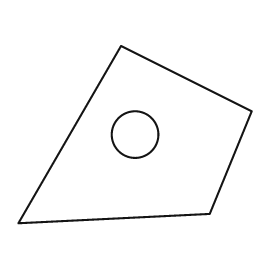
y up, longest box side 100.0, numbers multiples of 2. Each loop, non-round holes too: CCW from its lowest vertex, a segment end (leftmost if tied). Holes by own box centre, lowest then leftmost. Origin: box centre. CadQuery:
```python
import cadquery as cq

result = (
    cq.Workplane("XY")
    .moveTo(-50.0, -38.0)
    .lineTo(32.0, -34.0)
    .lineTo(50.0, 10.0)
    .lineTo(-6.0, 38.0)
    .close()
    .moveTo(0.0, 0.0)
    .circle(10.0)
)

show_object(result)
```